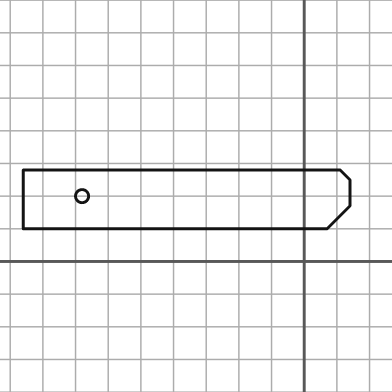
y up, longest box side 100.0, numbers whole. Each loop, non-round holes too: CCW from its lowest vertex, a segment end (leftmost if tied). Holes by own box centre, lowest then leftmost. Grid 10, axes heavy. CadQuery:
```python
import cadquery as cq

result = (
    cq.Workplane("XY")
    .moveTo(-86.0, 10.0)
    .lineTo(7.0, 10.0)
    .lineTo(14.0, 17.0)
    .lineTo(14.0, 25.0)
    .lineTo(11.0, 28.0)
    .lineTo(-86.0, 28.0)
    .close()
    .moveTo(-68.0, 20.0)
    .circle(2.0)
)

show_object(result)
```